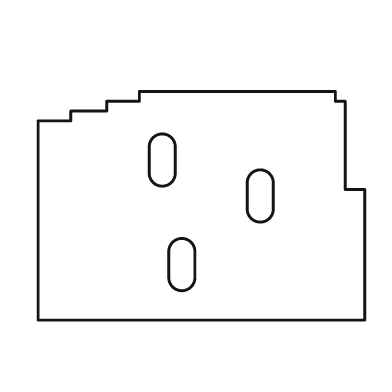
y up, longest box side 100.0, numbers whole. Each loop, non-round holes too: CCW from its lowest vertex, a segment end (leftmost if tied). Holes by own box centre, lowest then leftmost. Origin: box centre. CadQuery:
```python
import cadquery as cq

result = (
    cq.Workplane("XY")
    .moveTo(-50.0, -35.0)
    .lineTo(50.0, -35.0)
    .lineTo(50.0, 5.0)
    .lineTo(44.0, 5.0)
    .lineTo(44.0, 32.0)
    .lineTo(41.0, 32.0)
    .lineTo(41.0, 35.0)
    .lineTo(-19.0, 35.0)
    .lineTo(-19.0, 32.0)
    .lineTo(-29.0, 32.0)
    .lineTo(-29.0, 29.0)
    .lineTo(-40.0, 29.0)
    .lineTo(-40.0, 26.0)
    .lineTo(-50.0, 26.0)
    .close()
    .moveTo(-10.0, -22.0)
    .threePointArc((-6.0, -26.0), (-2.0, -22.0))
    .lineTo(-2.0, -14.0)
    .threePointArc((-6.0, -10.0), (-10.0, -14.0))
    .close()
    .moveTo(14.0, -1.0)
    .threePointArc((18.0, -5.0), (22.0, -1.0))
    .lineTo(22.0, 7.0)
    .threePointArc((18.0, 11.0), (14.0, 7.0))
    .close()
    .moveTo(-16.0, 10.0)
    .threePointArc((-12.0, 6.0), (-8.0, 10.0))
    .lineTo(-8.0, 18.0)
    .threePointArc((-12.0, 22.0), (-16.0, 18.0))
    .close()
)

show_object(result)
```